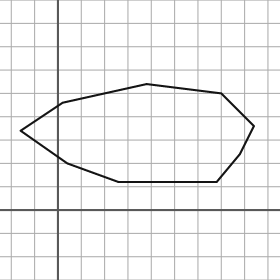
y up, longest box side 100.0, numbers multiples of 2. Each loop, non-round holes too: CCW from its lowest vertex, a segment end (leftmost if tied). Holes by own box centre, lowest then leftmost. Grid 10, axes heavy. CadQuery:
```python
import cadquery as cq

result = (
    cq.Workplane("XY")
    .moveTo(26.0, 12.0)
    .lineTo(68.0, 12.0)
    .lineTo(78.0, 24.0)
    .lineTo(84.0, 36.0)
    .lineTo(70.0, 50.0)
    .lineTo(38.0, 54.0)
    .lineTo(2.0, 46.0)
    .lineTo(-16.0, 34.0)
    .lineTo(4.0, 20.0)
    .close()
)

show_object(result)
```